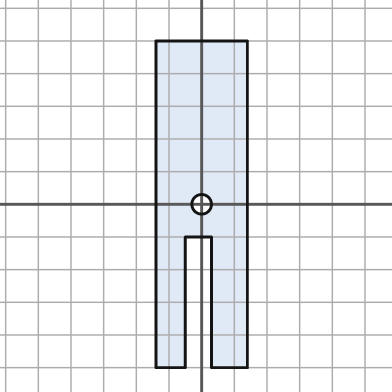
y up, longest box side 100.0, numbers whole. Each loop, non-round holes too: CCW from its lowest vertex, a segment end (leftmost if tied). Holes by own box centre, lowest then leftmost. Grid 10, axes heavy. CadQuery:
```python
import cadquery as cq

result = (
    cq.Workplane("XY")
    .moveTo(-14.0, -50.0)
    .lineTo(-5.0, -50.0)
    .lineTo(-5.0, -10.0)
    .lineTo(3.0, -10.0)
    .lineTo(3.0, -50.0)
    .lineTo(14.0, -50.0)
    .lineTo(14.0, 50.0)
    .lineTo(-14.0, 50.0)
    .close()
    .moveTo(0.0, 0.0)
    .circle(3.0)
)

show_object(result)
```